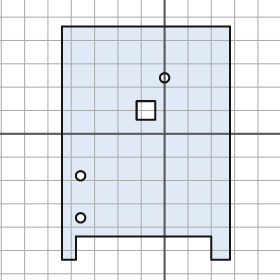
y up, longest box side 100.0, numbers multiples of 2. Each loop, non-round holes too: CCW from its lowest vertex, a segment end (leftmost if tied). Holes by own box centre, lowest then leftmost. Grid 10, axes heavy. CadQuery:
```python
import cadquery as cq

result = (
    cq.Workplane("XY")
    .moveTo(-44.0, -54.0)
    .lineTo(-38.0, -54.0)
    .lineTo(-38.0, -44.0)
    .lineTo(20.0, -44.0)
    .lineTo(20.0, -54.0)
    .lineTo(28.0, -54.0)
    .lineTo(28.0, 46.0)
    .lineTo(-44.0, 46.0)
    .close()
    .moveTo(-36.0, -36.0)
    .circle(2.0)
    .moveTo(-36.0, -18.0)
    .circle(2.0)
    .moveTo(-12.0, 6.0)
    .lineTo(-4.0, 6.0)
    .lineTo(-4.0, 14.0)
    .lineTo(-12.0, 14.0)
    .close()
    .moveTo(0.0, 24.0)
    .circle(2.0)
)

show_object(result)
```